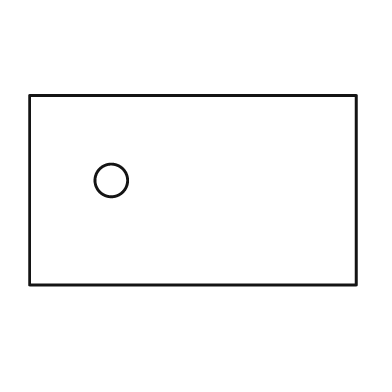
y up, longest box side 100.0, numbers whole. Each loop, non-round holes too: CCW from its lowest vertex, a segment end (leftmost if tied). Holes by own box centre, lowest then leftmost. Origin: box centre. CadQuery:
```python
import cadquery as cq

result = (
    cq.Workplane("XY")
    .moveTo(-50.0, -29.0)
    .lineTo(50.0, -29.0)
    .lineTo(50.0, 29.0)
    .lineTo(-50.0, 29.0)
    .close()
    .moveTo(-25.0, 3.0)
    .circle(5.0)
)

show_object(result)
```